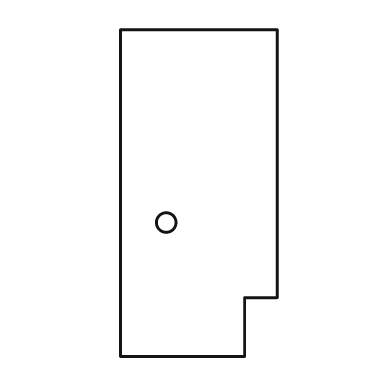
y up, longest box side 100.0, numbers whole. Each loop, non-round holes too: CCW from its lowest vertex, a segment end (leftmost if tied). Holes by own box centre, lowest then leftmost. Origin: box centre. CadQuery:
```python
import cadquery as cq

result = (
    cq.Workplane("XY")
    .moveTo(-24.0, -50.0)
    .lineTo(14.0, -50.0)
    .lineTo(14.0, -32.0)
    .lineTo(24.0, -32.0)
    .lineTo(24.0, 50.0)
    .lineTo(-24.0, 50.0)
    .close()
    .moveTo(-10.0, -9.0)
    .circle(3.0)
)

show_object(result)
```